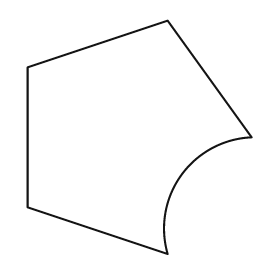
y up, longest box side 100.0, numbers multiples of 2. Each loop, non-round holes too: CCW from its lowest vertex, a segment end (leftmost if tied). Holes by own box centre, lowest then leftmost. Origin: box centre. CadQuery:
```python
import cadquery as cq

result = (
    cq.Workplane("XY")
    .moveTo(12.0, -50.0)
    .threePointArc((18.0, -16.0), (48.0, 0.0))
    .lineTo(12.0, 50.0)
    .lineTo(-48.0, 30.0)
    .lineTo(-48.0, -30.0)
    .close()
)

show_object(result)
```